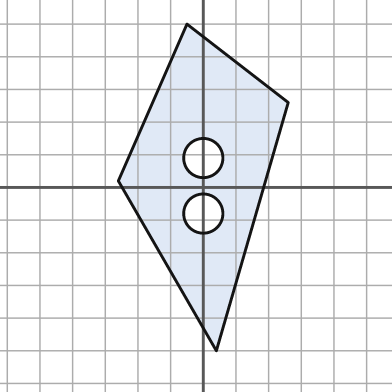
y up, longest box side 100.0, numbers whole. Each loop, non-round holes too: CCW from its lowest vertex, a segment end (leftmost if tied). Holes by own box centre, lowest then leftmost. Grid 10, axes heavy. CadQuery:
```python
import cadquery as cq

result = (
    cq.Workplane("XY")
    .moveTo(4.0, -50.0)
    .lineTo(26.0, 26.0)
    .lineTo(-5.0, 50.0)
    .lineTo(-26.0, 2.0)
    .close()
    .moveTo(0.0, -8.0)
    .circle(6.0)
    .moveTo(0.0, 9.0)
    .circle(6.0)
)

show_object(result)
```